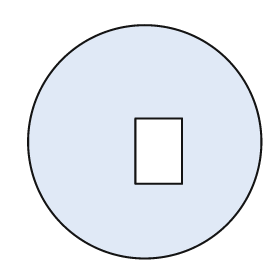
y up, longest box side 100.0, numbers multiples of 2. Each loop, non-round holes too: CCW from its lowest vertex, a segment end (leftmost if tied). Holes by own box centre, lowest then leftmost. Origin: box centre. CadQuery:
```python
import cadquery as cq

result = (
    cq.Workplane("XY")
    .moveTo(0.0, 0.0)
    .circle(50.0)
    .moveTo(-4.0, -18.0)
    .lineTo(16.0, -18.0)
    .lineTo(16.0, 10.0)
    .lineTo(-4.0, 10.0)
    .close()
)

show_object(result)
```